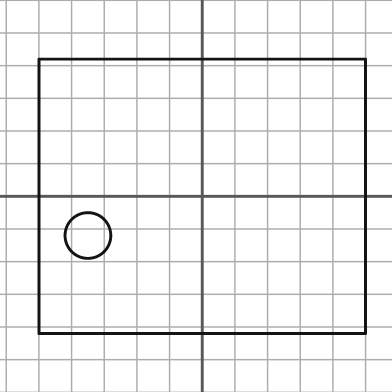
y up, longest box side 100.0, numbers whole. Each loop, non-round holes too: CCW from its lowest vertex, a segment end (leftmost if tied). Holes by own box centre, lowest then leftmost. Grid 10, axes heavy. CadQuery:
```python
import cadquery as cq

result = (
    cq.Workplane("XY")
    .moveTo(-50.0, -42.0)
    .lineTo(50.0, -42.0)
    .lineTo(50.0, 42.0)
    .lineTo(-50.0, 42.0)
    .close()
    .moveTo(-35.0, -12.0)
    .circle(7.0)
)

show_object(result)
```